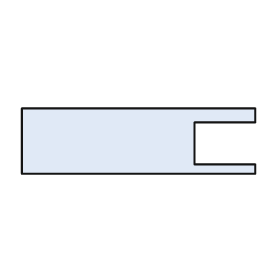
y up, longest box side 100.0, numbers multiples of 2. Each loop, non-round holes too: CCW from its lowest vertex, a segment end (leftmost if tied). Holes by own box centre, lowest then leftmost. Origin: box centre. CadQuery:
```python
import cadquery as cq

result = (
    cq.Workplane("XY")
    .moveTo(-50.0, -14.0)
    .lineTo(50.0, -14.0)
    .lineTo(50.0, -10.0)
    .lineTo(24.0, -10.0)
    .lineTo(24.0, 8.0)
    .lineTo(50.0, 8.0)
    .lineTo(50.0, 14.0)
    .lineTo(-50.0, 14.0)
    .close()
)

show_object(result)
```